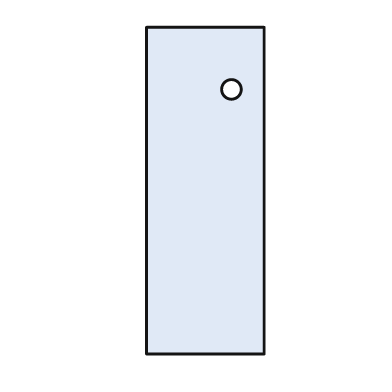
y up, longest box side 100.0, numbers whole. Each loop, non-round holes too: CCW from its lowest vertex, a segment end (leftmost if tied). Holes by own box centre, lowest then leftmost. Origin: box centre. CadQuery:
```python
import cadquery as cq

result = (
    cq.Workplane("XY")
    .moveTo(-18.0, -50.0)
    .lineTo(18.0, -50.0)
    .lineTo(18.0, 50.0)
    .lineTo(-18.0, 50.0)
    .close()
    .moveTo(8.0, 31.0)
    .circle(3.0)
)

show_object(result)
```